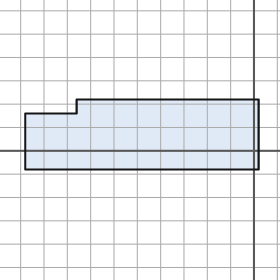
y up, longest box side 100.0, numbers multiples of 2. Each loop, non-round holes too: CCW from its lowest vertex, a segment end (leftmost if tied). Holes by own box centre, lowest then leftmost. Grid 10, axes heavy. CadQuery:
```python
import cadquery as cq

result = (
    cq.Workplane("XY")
    .moveTo(-98.0, -8.0)
    .lineTo(2.0, -8.0)
    .lineTo(2.0, 22.0)
    .lineTo(-76.0, 22.0)
    .lineTo(-76.0, 16.0)
    .lineTo(-98.0, 16.0)
    .close()
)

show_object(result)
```